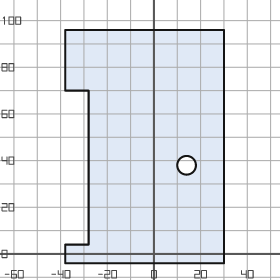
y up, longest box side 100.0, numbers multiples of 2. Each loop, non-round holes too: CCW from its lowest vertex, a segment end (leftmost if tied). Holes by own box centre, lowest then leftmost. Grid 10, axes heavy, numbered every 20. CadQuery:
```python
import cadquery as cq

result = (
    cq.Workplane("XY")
    .moveTo(-38.0, -4.0)
    .lineTo(30.0, -4.0)
    .lineTo(30.0, 96.0)
    .lineTo(-38.0, 96.0)
    .lineTo(-38.0, 70.0)
    .lineTo(-28.0, 70.0)
    .lineTo(-28.0, 4.0)
    .lineTo(-38.0, 4.0)
    .close()
    .moveTo(14.0, 38.0)
    .circle(4.0)
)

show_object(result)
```